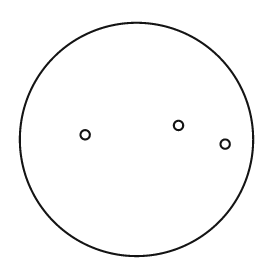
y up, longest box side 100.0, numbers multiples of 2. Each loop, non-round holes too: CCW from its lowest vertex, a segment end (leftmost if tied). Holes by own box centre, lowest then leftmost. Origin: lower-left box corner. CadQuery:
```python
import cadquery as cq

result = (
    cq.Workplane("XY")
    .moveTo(50.0, 50.0)
    .circle(50.0)
    .moveTo(88.0, 48.0)
    .circle(2.0)
    .moveTo(28.0, 52.0)
    .circle(2.0)
    .moveTo(68.0, 56.0)
    .circle(2.0)
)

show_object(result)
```